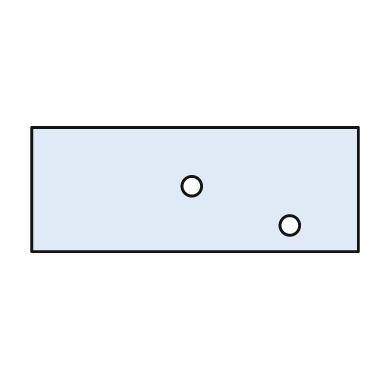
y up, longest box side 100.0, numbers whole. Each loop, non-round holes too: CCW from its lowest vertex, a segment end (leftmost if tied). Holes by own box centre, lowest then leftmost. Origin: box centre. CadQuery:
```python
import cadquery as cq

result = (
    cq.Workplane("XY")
    .moveTo(-50.0, -19.0)
    .lineTo(50.0, -19.0)
    .lineTo(50.0, 19.0)
    .lineTo(-50.0, 19.0)
    .close()
    .moveTo(29.0, -11.0)
    .circle(3.0)
    .moveTo(-1.0, 1.0)
    .circle(3.0)
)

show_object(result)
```